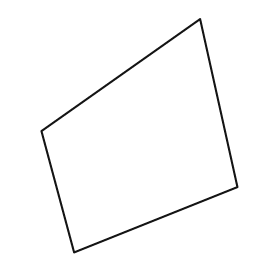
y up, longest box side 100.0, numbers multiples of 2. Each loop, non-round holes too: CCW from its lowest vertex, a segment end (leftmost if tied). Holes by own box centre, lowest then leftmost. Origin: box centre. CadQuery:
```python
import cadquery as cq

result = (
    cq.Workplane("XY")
    .moveTo(-28.0, -50.0)
    .lineTo(42.0, -22.0)
    .lineTo(26.0, 50.0)
    .lineTo(-42.0, 2.0)
    .close()
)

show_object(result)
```